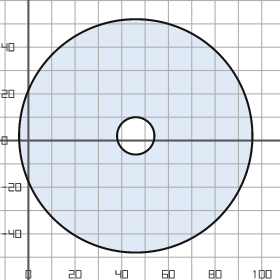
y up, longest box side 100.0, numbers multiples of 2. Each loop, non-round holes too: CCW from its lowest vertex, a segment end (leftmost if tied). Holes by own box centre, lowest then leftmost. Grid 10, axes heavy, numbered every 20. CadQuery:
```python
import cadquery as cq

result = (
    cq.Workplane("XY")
    .moveTo(46.0, 2.0)
    .circle(50.0)
    .moveTo(46.0, 2.0)
    .circle(8.0)
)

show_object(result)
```